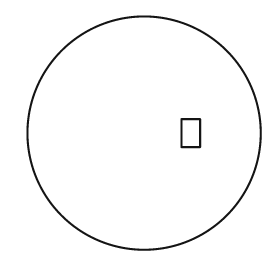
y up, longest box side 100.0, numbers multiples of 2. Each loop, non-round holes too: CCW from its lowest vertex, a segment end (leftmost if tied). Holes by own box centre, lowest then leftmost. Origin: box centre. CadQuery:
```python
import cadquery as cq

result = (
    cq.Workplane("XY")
    .moveTo(0.0, 0.0)
    .circle(50.0)
    .moveTo(16.0, -6.0)
    .lineTo(24.0, -6.0)
    .lineTo(24.0, 6.0)
    .lineTo(16.0, 6.0)
    .close()
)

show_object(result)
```